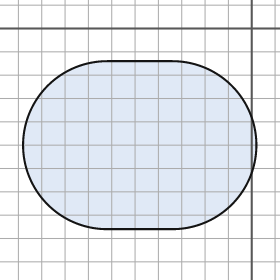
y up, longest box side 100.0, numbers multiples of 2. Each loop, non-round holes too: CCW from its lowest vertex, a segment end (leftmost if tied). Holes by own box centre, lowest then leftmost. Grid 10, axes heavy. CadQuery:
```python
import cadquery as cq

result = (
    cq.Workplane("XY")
    .moveTo(-62.0, -86.0)
    .lineTo(-34.0, -86.0)
    .threePointArc((2.0, -50.0), (-34.0, -14.0))
    .lineTo(-62.0, -14.0)
    .threePointArc((-98.0, -50.0), (-62.0, -86.0))
    .close()
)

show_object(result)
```